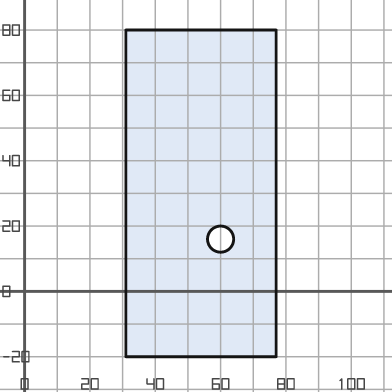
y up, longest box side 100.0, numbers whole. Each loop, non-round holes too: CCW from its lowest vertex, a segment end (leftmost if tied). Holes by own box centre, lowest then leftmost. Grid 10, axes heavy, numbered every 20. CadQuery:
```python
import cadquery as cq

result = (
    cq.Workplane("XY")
    .moveTo(31.0, -20.0)
    .lineTo(77.0, -20.0)
    .lineTo(77.0, 80.0)
    .lineTo(31.0, 80.0)
    .close()
    .moveTo(60.0, 16.0)
    .circle(4.0)
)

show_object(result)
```